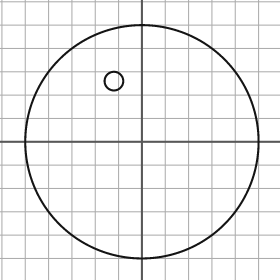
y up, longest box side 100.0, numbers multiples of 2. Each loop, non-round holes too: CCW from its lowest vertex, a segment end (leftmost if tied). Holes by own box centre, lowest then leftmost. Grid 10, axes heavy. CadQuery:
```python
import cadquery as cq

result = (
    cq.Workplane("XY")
    .moveTo(0.0, 0.0)
    .circle(50.0)
    .moveTo(-12.0, 26.0)
    .circle(4.0)
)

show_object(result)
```